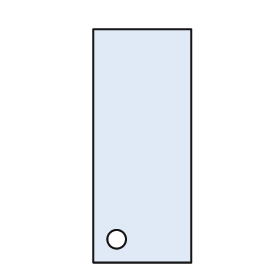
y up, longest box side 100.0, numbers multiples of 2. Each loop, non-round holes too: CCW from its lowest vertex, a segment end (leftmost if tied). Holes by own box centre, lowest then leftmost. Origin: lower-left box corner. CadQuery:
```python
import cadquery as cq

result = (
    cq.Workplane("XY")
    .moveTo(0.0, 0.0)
    .lineTo(42.0, 0.0)
    .lineTo(42.0, 100.0)
    .lineTo(0.0, 100.0)
    .close()
    .moveTo(10.0, 10.0)
    .circle(4.0)
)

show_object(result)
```